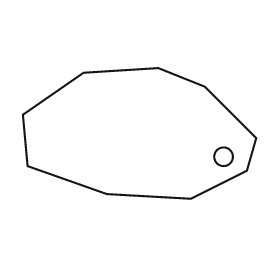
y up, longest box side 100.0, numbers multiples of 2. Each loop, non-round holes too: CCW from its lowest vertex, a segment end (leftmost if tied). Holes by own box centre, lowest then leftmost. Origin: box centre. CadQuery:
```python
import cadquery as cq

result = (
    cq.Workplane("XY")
    .moveTo(22.0, -28.0)
    .lineTo(46.0, -16.0)
    .lineTo(50.0, -2.0)
    .lineTo(28.0, 20.0)
    .lineTo(8.0, 28.0)
    .lineTo(-24.0, 26.0)
    .lineTo(-50.0, 8.0)
    .lineTo(-48.0, -14.0)
    .lineTo(-14.0, -26.0)
    .close()
    .moveTo(36.0, -10.0)
    .circle(4.0)
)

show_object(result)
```